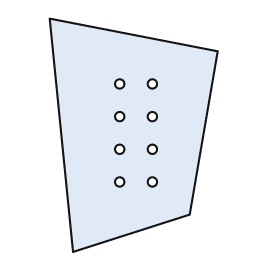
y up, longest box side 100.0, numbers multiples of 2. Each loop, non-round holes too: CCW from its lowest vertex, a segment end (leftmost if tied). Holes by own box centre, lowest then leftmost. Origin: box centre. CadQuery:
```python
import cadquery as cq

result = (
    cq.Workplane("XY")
    .moveTo(-26.0, -50.0)
    .lineTo(24.0, -34.0)
    .lineTo(36.0, 36.0)
    .lineTo(-36.0, 50.0)
    .close()
    .moveTo(-6.0, -20.0)
    .circle(2.0)
    .moveTo(8.0, -20.0)
    .circle(2.0)
    .moveTo(-6.0, -6.0)
    .circle(2.0)
    .moveTo(8.0, -6.0)
    .circle(2.0)
    .moveTo(-6.0, 8.0)
    .circle(2.0)
    .moveTo(8.0, 8.0)
    .circle(2.0)
    .moveTo(-6.0, 22.0)
    .circle(2.0)
    .moveTo(8.0, 22.0)
    .circle(2.0)
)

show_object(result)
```